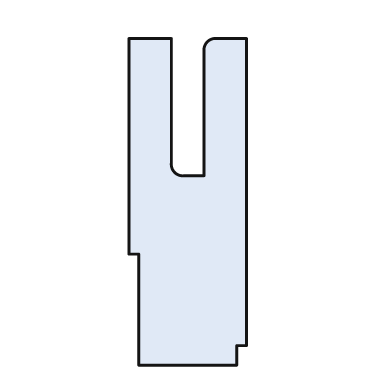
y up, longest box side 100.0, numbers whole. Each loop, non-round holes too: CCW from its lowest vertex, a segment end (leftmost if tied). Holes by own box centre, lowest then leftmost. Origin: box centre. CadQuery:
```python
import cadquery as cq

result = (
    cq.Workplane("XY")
    .moveTo(-15.0, -50.0)
    .lineTo(15.0, -50.0)
    .lineTo(15.0, -44.0)
    .lineTo(18.0, -44.0)
    .lineTo(18.0, 50.0)
    .lineTo(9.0, 50.0)
    .threePointArc((6.0, 49.0), (5.0, 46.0))
    .lineTo(5.0, 8.0)
    .lineTo(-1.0, 8.0)
    .threePointArc((-4.0, 9.0), (-5.0, 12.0))
    .lineTo(-5.0, 50.0)
    .lineTo(-18.0, 50.0)
    .lineTo(-18.0, -16.0)
    .lineTo(-15.0, -16.0)
    .close()
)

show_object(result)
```